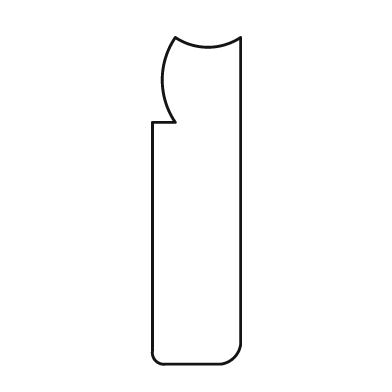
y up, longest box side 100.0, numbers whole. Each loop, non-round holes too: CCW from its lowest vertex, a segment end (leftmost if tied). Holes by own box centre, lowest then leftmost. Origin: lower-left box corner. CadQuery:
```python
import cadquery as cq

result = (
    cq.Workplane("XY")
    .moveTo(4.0, 0.0)
    .lineTo(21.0, 0.0)
    .threePointArc((25.0, 2.0), (27.0, 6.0))
    .lineTo(27.0, 100.0)
    .threePointArc((17.0, 97.0), (7.0, 100.0))
    .threePointArc((3.0, 87.0), (7.0, 74.0))
    .lineTo(0.0, 74.0)
    .lineTo(0.0, 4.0)
    .threePointArc((1.0, 1.0), (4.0, 0.0))
    .close()
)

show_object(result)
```